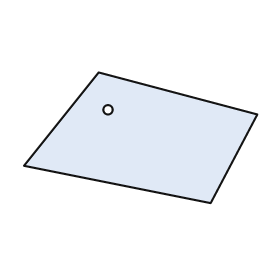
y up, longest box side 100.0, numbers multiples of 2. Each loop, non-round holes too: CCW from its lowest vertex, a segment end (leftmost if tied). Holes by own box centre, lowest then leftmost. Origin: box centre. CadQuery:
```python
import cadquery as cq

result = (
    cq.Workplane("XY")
    .moveTo(30.0, -28.0)
    .lineTo(50.0, 10.0)
    .lineTo(-18.0, 28.0)
    .lineTo(-50.0, -12.0)
    .close()
    .moveTo(-14.0, 12.0)
    .circle(2.0)
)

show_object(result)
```